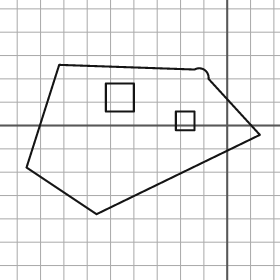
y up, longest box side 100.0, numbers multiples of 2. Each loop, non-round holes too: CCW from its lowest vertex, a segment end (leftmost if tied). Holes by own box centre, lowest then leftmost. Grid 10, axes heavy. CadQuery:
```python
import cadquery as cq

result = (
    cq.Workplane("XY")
    .moveTo(-56.0, -38.0)
    .lineTo(14.0, -4.0)
    .lineTo(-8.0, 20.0)
    .threePointArc((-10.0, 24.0), (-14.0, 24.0))
    .lineTo(-72.0, 26.0)
    .lineTo(-86.0, -18.0)
    .close()
    .moveTo(-22.0, -2.0)
    .lineTo(-14.0, -2.0)
    .lineTo(-14.0, 6.0)
    .lineTo(-22.0, 6.0)
    .close()
    .moveTo(-52.0, 6.0)
    .lineTo(-40.0, 6.0)
    .lineTo(-40.0, 18.0)
    .lineTo(-52.0, 18.0)
    .close()
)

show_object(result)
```